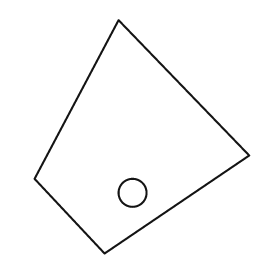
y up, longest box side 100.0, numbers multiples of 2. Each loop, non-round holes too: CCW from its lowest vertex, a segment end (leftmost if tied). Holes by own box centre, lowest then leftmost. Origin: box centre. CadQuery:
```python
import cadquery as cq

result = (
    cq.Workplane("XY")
    .moveTo(-16.0, -50.0)
    .lineTo(46.0, -8.0)
    .lineTo(-10.0, 50.0)
    .lineTo(-46.0, -18.0)
    .close()
    .moveTo(-4.0, -24.0)
    .circle(6.0)
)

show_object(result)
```